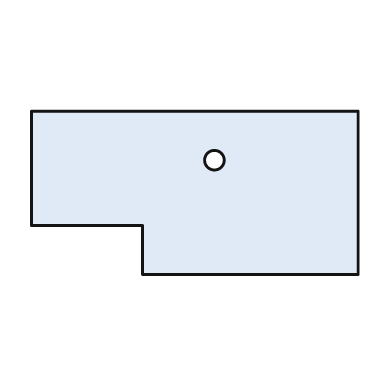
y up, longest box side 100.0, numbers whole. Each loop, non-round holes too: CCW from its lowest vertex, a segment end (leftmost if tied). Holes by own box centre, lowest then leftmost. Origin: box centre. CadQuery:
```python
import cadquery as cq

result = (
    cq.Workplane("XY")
    .moveTo(-16.0, -25.0)
    .lineTo(50.0, -25.0)
    .lineTo(50.0, 25.0)
    .lineTo(-50.0, 25.0)
    .lineTo(-50.0, -10.0)
    .lineTo(-16.0, -10.0)
    .close()
    .moveTo(6.0, 10.0)
    .circle(3.0)
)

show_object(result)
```